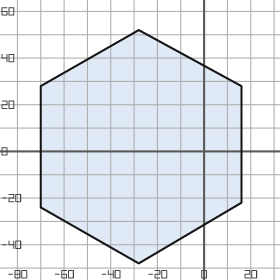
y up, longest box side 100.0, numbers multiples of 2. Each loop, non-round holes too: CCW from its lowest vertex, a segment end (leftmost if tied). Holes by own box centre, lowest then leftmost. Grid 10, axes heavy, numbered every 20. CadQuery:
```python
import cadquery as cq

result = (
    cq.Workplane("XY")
    .moveTo(-28.0, -48.0)
    .lineTo(16.0, -22.0)
    .lineTo(16.0, 28.0)
    .lineTo(-28.0, 52.0)
    .lineTo(-70.0, 28.0)
    .lineTo(-70.0, -24.0)
    .close()
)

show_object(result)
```